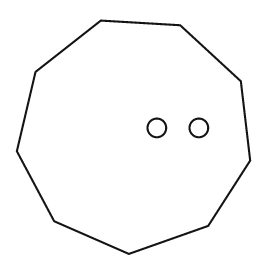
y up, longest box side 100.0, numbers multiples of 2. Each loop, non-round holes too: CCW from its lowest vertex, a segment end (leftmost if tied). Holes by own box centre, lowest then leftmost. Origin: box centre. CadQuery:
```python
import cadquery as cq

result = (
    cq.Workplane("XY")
    .moveTo(-2.0, -50.0)
    .lineTo(32.0, -38.0)
    .lineTo(50.0, -10.0)
    .lineTo(46.0, 24.0)
    .lineTo(20.0, 48.0)
    .lineTo(-14.0, 50.0)
    .lineTo(-42.0, 28.0)
    .lineTo(-50.0, -6.0)
    .lineTo(-34.0, -36.0)
    .close()
    .moveTo(10.0, 4.0)
    .circle(4.0)
    .moveTo(28.0, 4.0)
    .circle(4.0)
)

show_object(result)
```